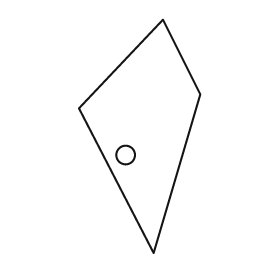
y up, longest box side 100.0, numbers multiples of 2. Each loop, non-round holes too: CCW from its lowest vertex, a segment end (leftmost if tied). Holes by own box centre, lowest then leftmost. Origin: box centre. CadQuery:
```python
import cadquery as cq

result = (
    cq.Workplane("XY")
    .moveTo(6.0, -50.0)
    .lineTo(26.0, 18.0)
    .lineTo(10.0, 50.0)
    .lineTo(-26.0, 12.0)
    .close()
    .moveTo(-6.0, -8.0)
    .circle(4.0)
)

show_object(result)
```